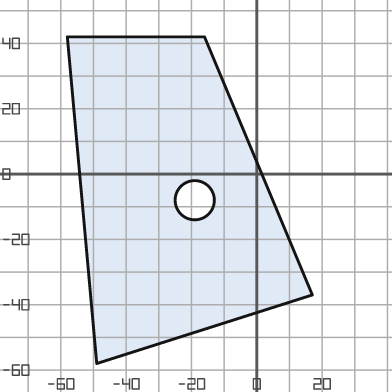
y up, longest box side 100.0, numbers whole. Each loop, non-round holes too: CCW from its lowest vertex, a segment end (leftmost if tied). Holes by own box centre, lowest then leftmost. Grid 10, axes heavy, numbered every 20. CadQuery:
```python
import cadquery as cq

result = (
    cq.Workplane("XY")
    .moveTo(-49.0, -58.0)
    .lineTo(17.0, -37.0)
    .lineTo(-16.0, 42.0)
    .lineTo(-58.0, 42.0)
    .close()
    .moveTo(-19.0, -8.0)
    .circle(6.0)
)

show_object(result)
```